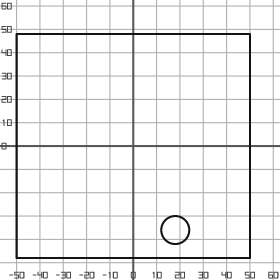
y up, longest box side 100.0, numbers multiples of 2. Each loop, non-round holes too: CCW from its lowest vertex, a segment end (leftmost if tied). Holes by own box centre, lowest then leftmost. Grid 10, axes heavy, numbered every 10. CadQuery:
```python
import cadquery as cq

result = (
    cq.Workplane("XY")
    .moveTo(-50.0, -48.0)
    .lineTo(50.0, -48.0)
    .lineTo(50.0, 48.0)
    .lineTo(-50.0, 48.0)
    .close()
    .moveTo(18.0, -36.0)
    .circle(6.0)
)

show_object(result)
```